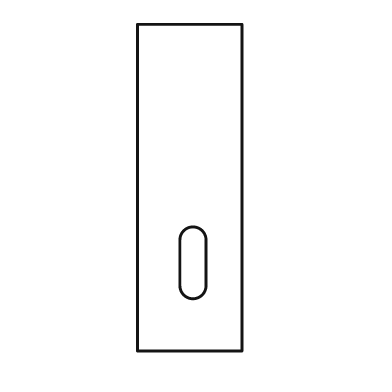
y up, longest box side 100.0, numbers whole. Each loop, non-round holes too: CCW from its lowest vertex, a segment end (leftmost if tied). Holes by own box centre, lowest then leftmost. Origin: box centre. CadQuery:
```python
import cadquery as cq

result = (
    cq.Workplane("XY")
    .moveTo(-16.0, -50.0)
    .lineTo(16.0, -50.0)
    .lineTo(16.0, 50.0)
    .lineTo(-16.0, 50.0)
    .close()
    .moveTo(-3.0, -30.0)
    .threePointArc((1.0, -34.0), (5.0, -30.0))
    .lineTo(5.0, -16.0)
    .threePointArc((1.0, -12.0), (-3.0, -16.0))
    .close()
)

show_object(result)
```